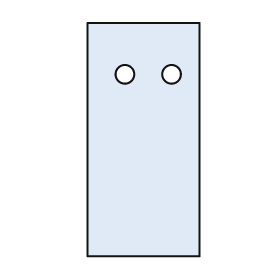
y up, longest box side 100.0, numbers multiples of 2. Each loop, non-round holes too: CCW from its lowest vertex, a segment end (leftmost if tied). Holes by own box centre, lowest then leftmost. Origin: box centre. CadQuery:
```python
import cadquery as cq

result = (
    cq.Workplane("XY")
    .moveTo(-24.0, -50.0)
    .lineTo(24.0, -50.0)
    .lineTo(24.0, 50.0)
    .lineTo(-24.0, 50.0)
    .close()
    .moveTo(-8.0, 28.0)
    .circle(4.0)
    .moveTo(12.0, 28.0)
    .circle(4.0)
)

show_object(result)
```